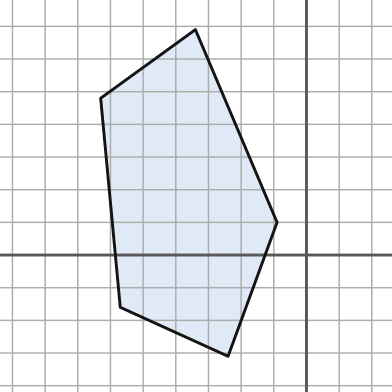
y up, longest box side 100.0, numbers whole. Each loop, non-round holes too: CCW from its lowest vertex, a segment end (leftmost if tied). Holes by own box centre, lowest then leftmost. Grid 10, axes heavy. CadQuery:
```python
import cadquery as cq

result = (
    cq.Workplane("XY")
    .moveTo(-24.0, -31.0)
    .lineTo(-9.0, 10.0)
    .lineTo(-34.0, 69.0)
    .lineTo(-63.0, 48.0)
    .lineTo(-57.0, -16.0)
    .close()
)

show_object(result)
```